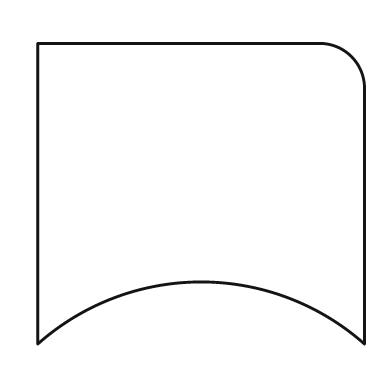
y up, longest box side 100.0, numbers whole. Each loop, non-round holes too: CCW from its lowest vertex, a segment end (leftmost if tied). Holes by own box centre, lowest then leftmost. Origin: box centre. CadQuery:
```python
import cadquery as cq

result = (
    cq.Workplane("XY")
    .moveTo(-50.0, -46.0)
    .threePointArc((0.0, -27.0), (50.0, -46.0))
    .lineTo(50.0, 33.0)
    .threePointArc((46.0, 42.0), (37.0, 46.0))
    .lineTo(-50.0, 46.0)
    .close()
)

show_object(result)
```